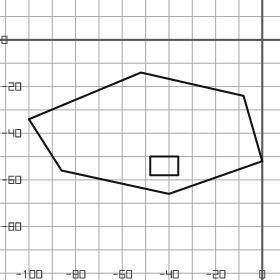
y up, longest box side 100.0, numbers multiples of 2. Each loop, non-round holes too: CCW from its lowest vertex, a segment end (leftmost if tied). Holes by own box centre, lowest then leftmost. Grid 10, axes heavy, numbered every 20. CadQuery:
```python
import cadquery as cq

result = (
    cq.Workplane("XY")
    .moveTo(-40.0, -66.0)
    .lineTo(0.0, -52.0)
    .lineTo(-8.0, -24.0)
    .lineTo(-52.0, -14.0)
    .lineTo(-100.0, -34.0)
    .lineTo(-86.0, -56.0)
    .close()
    .moveTo(-48.0, -58.0)
    .lineTo(-36.0, -58.0)
    .lineTo(-36.0, -50.0)
    .lineTo(-48.0, -50.0)
    .close()
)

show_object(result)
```